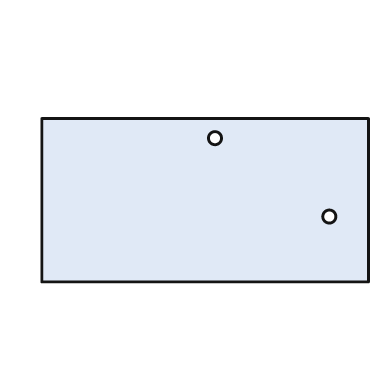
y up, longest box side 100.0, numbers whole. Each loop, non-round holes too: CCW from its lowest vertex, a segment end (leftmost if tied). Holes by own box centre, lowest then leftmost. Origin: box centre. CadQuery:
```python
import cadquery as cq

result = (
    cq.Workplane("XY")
    .moveTo(-50.0, -25.0)
    .lineTo(50.0, -25.0)
    .lineTo(50.0, 25.0)
    .lineTo(-50.0, 25.0)
    .close()
    .moveTo(38.0, -5.0)
    .circle(2.0)
    .moveTo(3.0, 19.0)
    .circle(2.0)
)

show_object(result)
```